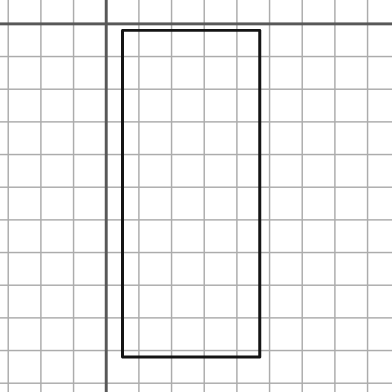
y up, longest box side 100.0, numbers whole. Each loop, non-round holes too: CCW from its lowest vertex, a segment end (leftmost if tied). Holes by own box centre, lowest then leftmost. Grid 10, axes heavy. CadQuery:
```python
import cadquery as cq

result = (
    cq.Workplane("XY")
    .moveTo(5.0, -102.0)
    .lineTo(47.0, -102.0)
    .lineTo(47.0, -2.0)
    .lineTo(5.0, -2.0)
    .close()
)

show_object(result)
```